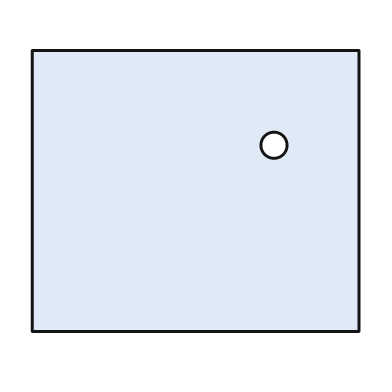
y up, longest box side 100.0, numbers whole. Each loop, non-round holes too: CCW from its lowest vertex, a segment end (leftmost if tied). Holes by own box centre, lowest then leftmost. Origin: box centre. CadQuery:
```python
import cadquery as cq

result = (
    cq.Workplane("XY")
    .moveTo(-50.0, -43.0)
    .lineTo(50.0, -43.0)
    .lineTo(50.0, 43.0)
    .lineTo(-50.0, 43.0)
    .close()
    .moveTo(24.0, 14.0)
    .circle(4.0)
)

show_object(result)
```